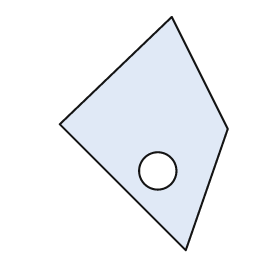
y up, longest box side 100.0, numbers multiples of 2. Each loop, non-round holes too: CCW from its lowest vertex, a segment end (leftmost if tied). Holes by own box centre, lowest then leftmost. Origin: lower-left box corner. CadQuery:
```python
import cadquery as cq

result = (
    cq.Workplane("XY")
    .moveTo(54.0, 0.0)
    .lineTo(72.0, 52.0)
    .lineTo(48.0, 100.0)
    .lineTo(0.0, 54.0)
    .close()
    .moveTo(42.0, 34.0)
    .circle(8.0)
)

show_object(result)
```